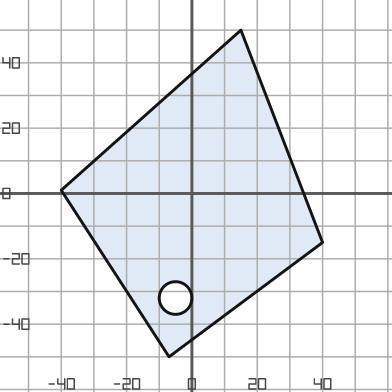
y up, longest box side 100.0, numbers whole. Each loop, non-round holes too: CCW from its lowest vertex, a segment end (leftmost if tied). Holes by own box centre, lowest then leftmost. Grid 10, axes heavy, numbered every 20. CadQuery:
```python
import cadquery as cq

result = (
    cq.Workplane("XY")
    .moveTo(-7.0, -50.0)
    .lineTo(40.0, -15.0)
    .lineTo(15.0, 50.0)
    .lineTo(-40.0, 1.0)
    .close()
    .moveTo(-5.0, -32.0)
    .circle(5.0)
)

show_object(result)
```